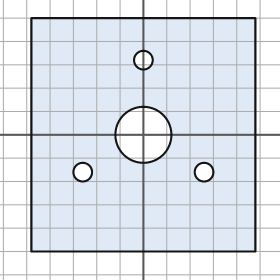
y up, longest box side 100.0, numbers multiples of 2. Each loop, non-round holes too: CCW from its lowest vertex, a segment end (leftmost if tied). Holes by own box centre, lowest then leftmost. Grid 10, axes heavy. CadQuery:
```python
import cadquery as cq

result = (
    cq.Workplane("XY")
    .moveTo(-48.0, -50.0)
    .lineTo(48.0, -50.0)
    .lineTo(48.0, 50.0)
    .lineTo(-48.0, 50.0)
    .close()
    .moveTo(-26.0, -16.0)
    .circle(4.0)
    .moveTo(26.0, -16.0)
    .circle(4.0)
    .moveTo(0.0, 0.0)
    .circle(12.0)
    .moveTo(0.0, 32.0)
    .circle(4.0)
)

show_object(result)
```